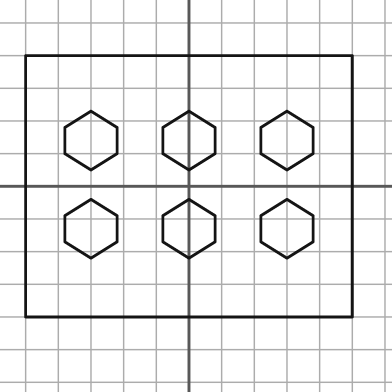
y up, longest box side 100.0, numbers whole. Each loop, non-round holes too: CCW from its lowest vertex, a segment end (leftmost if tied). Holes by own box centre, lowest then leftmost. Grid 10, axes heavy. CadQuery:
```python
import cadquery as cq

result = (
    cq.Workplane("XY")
    .moveTo(-50.0, -40.0)
    .lineTo(50.0, -40.0)
    .lineTo(50.0, 40.0)
    .lineTo(-50.0, 40.0)
    .close()
    .moveTo(-30.0, -22.0)
    .lineTo(-22.0, -17.0)
    .lineTo(-22.0, -9.0)
    .lineTo(-30.0, -4.0)
    .lineTo(-38.0, -9.0)
    .lineTo(-38.0, -17.0)
    .close()
    .moveTo(0.0, -22.0)
    .lineTo(8.0, -17.0)
    .lineTo(8.0, -9.0)
    .lineTo(0.0, -4.0)
    .lineTo(-8.0, -9.0)
    .lineTo(-8.0, -17.0)
    .close()
    .moveTo(30.0, -22.0)
    .lineTo(38.0, -17.0)
    .lineTo(38.0, -9.0)
    .lineTo(30.0, -4.0)
    .lineTo(22.0, -9.0)
    .lineTo(22.0, -17.0)
    .close()
    .moveTo(-30.0, 5.0)
    .lineTo(-22.0, 10.0)
    .lineTo(-22.0, 18.0)
    .lineTo(-30.0, 23.0)
    .lineTo(-38.0, 18.0)
    .lineTo(-38.0, 10.0)
    .close()
    .moveTo(0.0, 5.0)
    .lineTo(8.0, 10.0)
    .lineTo(8.0, 18.0)
    .lineTo(0.0, 23.0)
    .lineTo(-8.0, 18.0)
    .lineTo(-8.0, 10.0)
    .close()
    .moveTo(30.0, 5.0)
    .lineTo(38.0, 10.0)
    .lineTo(38.0, 18.0)
    .lineTo(30.0, 23.0)
    .lineTo(22.0, 18.0)
    .lineTo(22.0, 10.0)
    .close()
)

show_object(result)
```